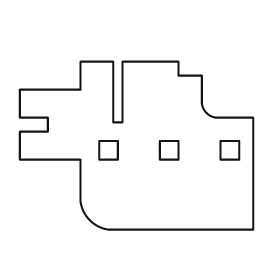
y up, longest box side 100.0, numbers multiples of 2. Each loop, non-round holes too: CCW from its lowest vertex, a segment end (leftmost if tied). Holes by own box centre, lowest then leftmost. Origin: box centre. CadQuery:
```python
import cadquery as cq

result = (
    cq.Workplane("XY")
    .moveTo(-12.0, -36.0)
    .lineTo(50.0, -36.0)
    .lineTo(50.0, 12.0)
    .lineTo(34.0, 12.0)
    .threePointArc((30.0, 14.0), (28.0, 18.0))
    .lineTo(28.0, 30.0)
    .lineTo(18.0, 30.0)
    .lineTo(18.0, 36.0)
    .lineTo(-6.0, 36.0)
    .lineTo(-6.0, 10.0)
    .lineTo(-10.0, 10.0)
    .lineTo(-10.0, 36.0)
    .lineTo(-24.0, 36.0)
    .lineTo(-24.0, 24.0)
    .lineTo(-50.0, 24.0)
    .lineTo(-50.0, 12.0)
    .lineTo(-38.0, 12.0)
    .lineTo(-38.0, 6.0)
    .lineTo(-50.0, 6.0)
    .lineTo(-50.0, -6.0)
    .lineTo(-24.0, -6.0)
    .lineTo(-24.0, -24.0)
    .threePointArc((-20.0, -32.0), (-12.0, -36.0))
    .close()
    .moveTo(-16.0, -6.0)
    .lineTo(-8.0, -6.0)
    .lineTo(-8.0, 2.0)
    .lineTo(-16.0, 2.0)
    .close()
    .moveTo(10.0, -6.0)
    .lineTo(18.0, -6.0)
    .lineTo(18.0, 2.0)
    .lineTo(10.0, 2.0)
    .close()
    .moveTo(36.0, -6.0)
    .lineTo(44.0, -6.0)
    .lineTo(44.0, 2.0)
    .lineTo(36.0, 2.0)
    .close()
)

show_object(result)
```